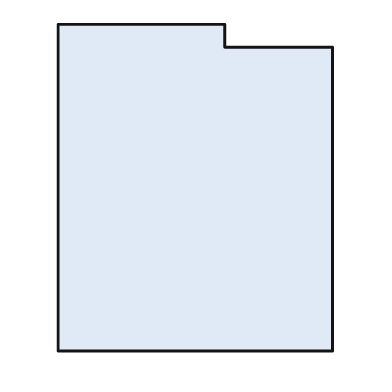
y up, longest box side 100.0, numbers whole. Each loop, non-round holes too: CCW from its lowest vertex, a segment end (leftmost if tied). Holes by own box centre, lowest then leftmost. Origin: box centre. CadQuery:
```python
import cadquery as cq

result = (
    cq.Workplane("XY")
    .moveTo(-42.0, -50.0)
    .lineTo(42.0, -50.0)
    .lineTo(42.0, 43.0)
    .lineTo(9.0, 43.0)
    .lineTo(9.0, 50.0)
    .lineTo(-42.0, 50.0)
    .close()
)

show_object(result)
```